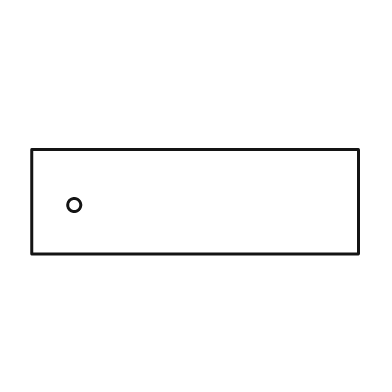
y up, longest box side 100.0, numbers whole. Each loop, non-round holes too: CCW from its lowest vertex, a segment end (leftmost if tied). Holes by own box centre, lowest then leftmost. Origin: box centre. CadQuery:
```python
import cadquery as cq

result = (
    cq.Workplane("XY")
    .moveTo(-50.0, -16.0)
    .lineTo(50.0, -16.0)
    .lineTo(50.0, 16.0)
    .lineTo(-50.0, 16.0)
    .close()
    .moveTo(-37.0, -1.0)
    .circle(2.0)
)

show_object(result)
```